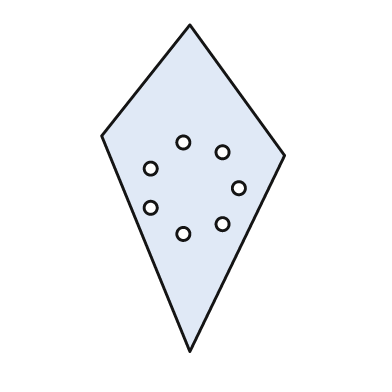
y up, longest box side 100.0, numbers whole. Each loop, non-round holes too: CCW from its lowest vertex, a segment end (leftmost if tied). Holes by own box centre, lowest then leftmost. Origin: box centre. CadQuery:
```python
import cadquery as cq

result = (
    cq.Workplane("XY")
    .moveTo(-1.0, -50.0)
    .lineTo(28.0, 10.0)
    .lineTo(-1.0, 50.0)
    .lineTo(-28.0, 16.0)
    .close()
    .moveTo(-3.0, -14.0)
    .circle(2.0)
    .moveTo(9.0, -11.0)
    .circle(2.0)
    .moveTo(-13.0, -6.0)
    .circle(2.0)
    .moveTo(14.0, 0.0)
    .circle(2.0)
    .moveTo(-13.0, 6.0)
    .circle(2.0)
    .moveTo(9.0, 11.0)
    .circle(2.0)
    .moveTo(-3.0, 14.0)
    .circle(2.0)
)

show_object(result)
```